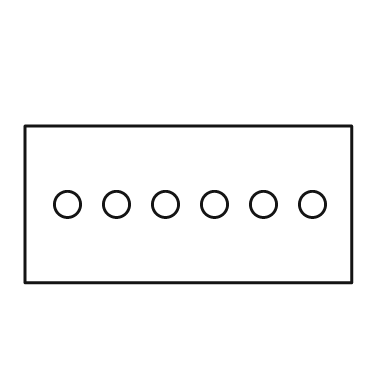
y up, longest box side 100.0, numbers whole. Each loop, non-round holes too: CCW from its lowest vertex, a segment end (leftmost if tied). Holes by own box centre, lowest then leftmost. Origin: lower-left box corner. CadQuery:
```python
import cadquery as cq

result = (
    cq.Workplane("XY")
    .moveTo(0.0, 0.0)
    .lineTo(100.0, 0.0)
    .lineTo(100.0, 48.0)
    .lineTo(0.0, 48.0)
    .close()
    .moveTo(13.0, 24.0)
    .circle(4.0)
    .moveTo(28.0, 24.0)
    .circle(4.0)
    .moveTo(43.0, 24.0)
    .circle(4.0)
    .moveTo(58.0, 24.0)
    .circle(4.0)
    .moveTo(73.0, 24.0)
    .circle(4.0)
    .moveTo(88.0, 24.0)
    .circle(4.0)
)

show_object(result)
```